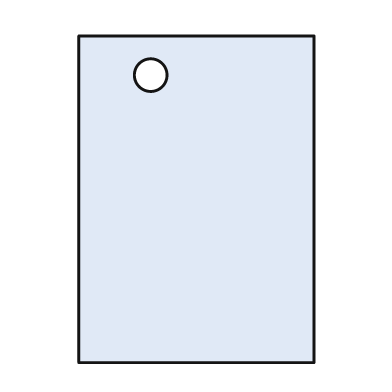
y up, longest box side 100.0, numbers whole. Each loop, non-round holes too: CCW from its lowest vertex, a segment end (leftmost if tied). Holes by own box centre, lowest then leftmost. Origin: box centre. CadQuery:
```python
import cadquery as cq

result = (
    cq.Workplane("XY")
    .moveTo(-36.0, -50.0)
    .lineTo(36.0, -50.0)
    .lineTo(36.0, 50.0)
    .lineTo(-36.0, 50.0)
    .close()
    .moveTo(-14.0, 38.0)
    .circle(5.0)
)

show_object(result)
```